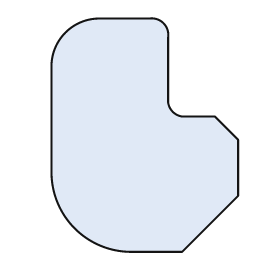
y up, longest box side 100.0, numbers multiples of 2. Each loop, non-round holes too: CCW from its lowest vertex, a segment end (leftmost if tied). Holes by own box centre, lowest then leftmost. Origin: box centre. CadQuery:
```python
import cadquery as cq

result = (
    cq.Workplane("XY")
    .moveTo(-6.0, -50.0)
    .lineTo(16.0, -50.0)
    .lineTo(40.0, -26.0)
    .lineTo(40.0, -2.0)
    .lineTo(30.0, 8.0)
    .lineTo(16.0, 8.0)
    .threePointArc((12.0, 10.0), (10.0, 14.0))
    .lineTo(10.0, 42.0)
    .threePointArc((8.0, 48.0), (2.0, 50.0))
    .lineTo(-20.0, 50.0)
    .threePointArc((-34.0, 44.0), (-40.0, 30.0))
    .lineTo(-40.0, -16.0)
    .threePointArc((-30.0, -40.0), (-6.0, -50.0))
    .close()
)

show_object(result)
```